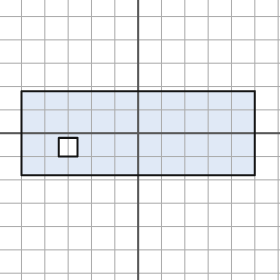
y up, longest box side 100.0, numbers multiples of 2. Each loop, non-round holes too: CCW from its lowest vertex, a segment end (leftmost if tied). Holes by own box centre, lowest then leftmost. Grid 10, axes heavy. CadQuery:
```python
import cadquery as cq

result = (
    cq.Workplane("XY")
    .moveTo(-50.0, -18.0)
    .lineTo(50.0, -18.0)
    .lineTo(50.0, 18.0)
    .lineTo(-50.0, 18.0)
    .close()
    .moveTo(-34.0, -10.0)
    .lineTo(-26.0, -10.0)
    .lineTo(-26.0, -2.0)
    .lineTo(-34.0, -2.0)
    .close()
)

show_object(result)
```